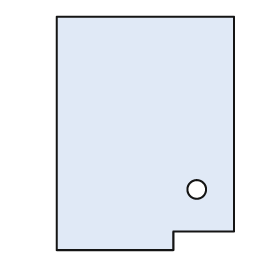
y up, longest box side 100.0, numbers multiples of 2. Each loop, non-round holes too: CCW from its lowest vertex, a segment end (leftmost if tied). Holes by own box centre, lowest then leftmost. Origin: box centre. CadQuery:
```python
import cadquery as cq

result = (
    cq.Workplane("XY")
    .moveTo(-38.0, -50.0)
    .lineTo(12.0, -50.0)
    .lineTo(12.0, -42.0)
    .lineTo(38.0, -42.0)
    .lineTo(38.0, 50.0)
    .lineTo(-38.0, 50.0)
    .close()
    .moveTo(22.0, -24.0)
    .circle(4.0)
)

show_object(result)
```